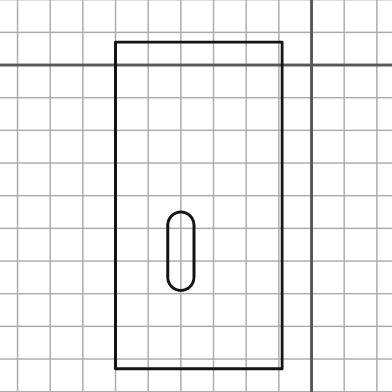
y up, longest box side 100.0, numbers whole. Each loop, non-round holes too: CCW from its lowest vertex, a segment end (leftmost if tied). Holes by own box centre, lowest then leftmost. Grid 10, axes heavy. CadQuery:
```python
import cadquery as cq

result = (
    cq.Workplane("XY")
    .moveTo(-60.0, -93.0)
    .lineTo(-9.0, -93.0)
    .lineTo(-9.0, 7.0)
    .lineTo(-60.0, 7.0)
    .close()
    .moveTo(-44.0, -65.0)
    .threePointArc((-40.0, -69.0), (-36.0, -65.0))
    .lineTo(-36.0, -49.0)
    .threePointArc((-40.0, -45.0), (-44.0, -49.0))
    .close()
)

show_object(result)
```